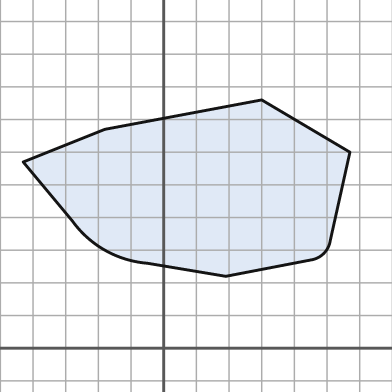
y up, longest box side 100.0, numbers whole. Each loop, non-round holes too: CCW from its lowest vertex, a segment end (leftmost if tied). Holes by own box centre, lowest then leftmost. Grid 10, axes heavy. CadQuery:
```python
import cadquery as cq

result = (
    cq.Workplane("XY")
    .moveTo(19.0, 22.0)
    .lineTo(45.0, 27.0)
    .threePointArc((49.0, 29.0), (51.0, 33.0))
    .lineTo(57.0, 60.0)
    .lineTo(30.0, 76.0)
    .lineTo(-18.0, 67.0)
    .lineTo(-43.0, 57.0)
    .lineTo(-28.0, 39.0)
    .threePointArc((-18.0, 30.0), (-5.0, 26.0))
    .close()
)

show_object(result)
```